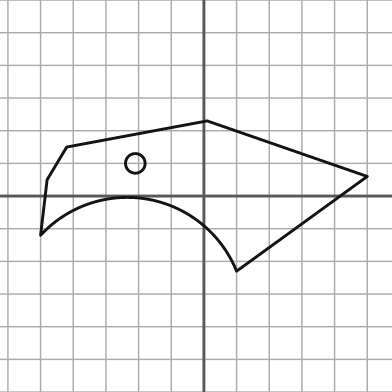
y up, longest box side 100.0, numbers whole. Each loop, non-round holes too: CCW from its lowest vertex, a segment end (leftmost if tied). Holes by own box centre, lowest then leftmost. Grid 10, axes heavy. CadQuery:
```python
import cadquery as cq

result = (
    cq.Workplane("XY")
    .moveTo(10.0, -23.0)
    .lineTo(50.0, 6.0)
    .lineTo(1.0, 23.0)
    .lineTo(-42.0, 15.0)
    .lineTo(-48.0, 5.0)
    .lineTo(-50.0, -12.0)
    .threePointArc((-17.0, -1.0), (10.0, -23.0))
    .close()
    .moveTo(-21.0, 10.0)
    .circle(3.0)
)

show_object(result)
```